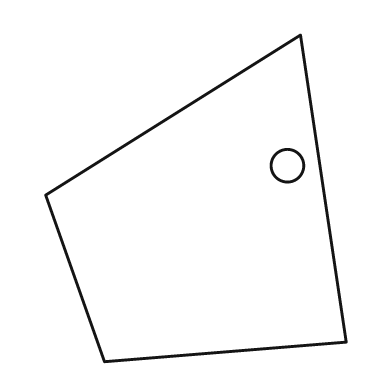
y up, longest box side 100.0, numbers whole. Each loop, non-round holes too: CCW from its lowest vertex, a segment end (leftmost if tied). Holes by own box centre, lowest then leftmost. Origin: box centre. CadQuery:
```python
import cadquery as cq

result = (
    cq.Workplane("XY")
    .moveTo(-28.0, -50.0)
    .lineTo(46.0, -44.0)
    .lineTo(32.0, 50.0)
    .lineTo(-46.0, 1.0)
    .close()
    .moveTo(28.0, 10.0)
    .circle(5.0)
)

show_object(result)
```